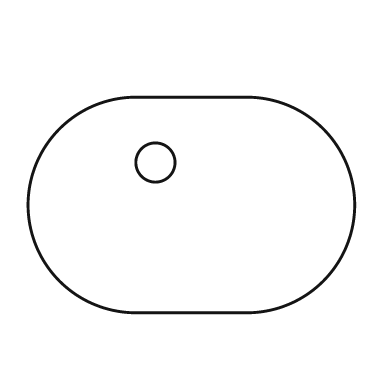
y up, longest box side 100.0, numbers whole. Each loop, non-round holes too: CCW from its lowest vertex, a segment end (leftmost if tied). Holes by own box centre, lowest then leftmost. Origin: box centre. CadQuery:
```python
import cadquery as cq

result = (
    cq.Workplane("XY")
    .moveTo(-17.0, -33.0)
    .lineTo(17.0, -33.0)
    .threePointArc((50.0, 0.0), (17.0, 33.0))
    .lineTo(-17.0, 33.0)
    .threePointArc((-50.0, 0.0), (-17.0, -33.0))
    .close()
    .moveTo(-11.0, 13.0)
    .circle(6.0)
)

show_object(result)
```